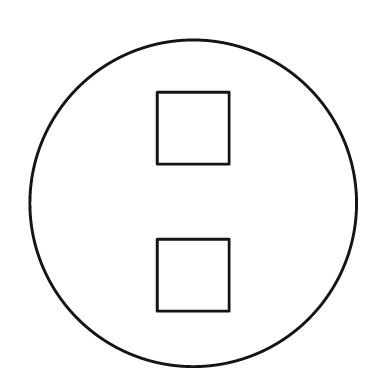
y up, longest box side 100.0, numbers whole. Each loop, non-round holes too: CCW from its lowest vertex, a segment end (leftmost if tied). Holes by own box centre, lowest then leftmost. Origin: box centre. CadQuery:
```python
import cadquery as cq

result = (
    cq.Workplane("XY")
    .moveTo(0.0, 0.0)
    .circle(50.0)
    .moveTo(-11.0, -33.0)
    .lineTo(11.0, -33.0)
    .lineTo(11.0, -11.0)
    .lineTo(-11.0, -11.0)
    .close()
    .moveTo(-11.0, 12.0)
    .lineTo(11.0, 12.0)
    .lineTo(11.0, 34.0)
    .lineTo(-11.0, 34.0)
    .close()
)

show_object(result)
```